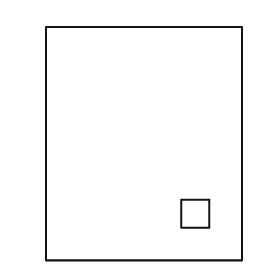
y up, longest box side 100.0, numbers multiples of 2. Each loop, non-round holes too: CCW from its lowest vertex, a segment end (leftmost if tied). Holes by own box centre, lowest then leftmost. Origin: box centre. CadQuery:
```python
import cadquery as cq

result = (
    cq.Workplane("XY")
    .moveTo(-42.0, -50.0)
    .lineTo(42.0, -50.0)
    .lineTo(42.0, 50.0)
    .lineTo(-42.0, 50.0)
    .close()
    .moveTo(16.0, -36.0)
    .lineTo(28.0, -36.0)
    .lineTo(28.0, -24.0)
    .lineTo(16.0, -24.0)
    .close()
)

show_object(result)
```